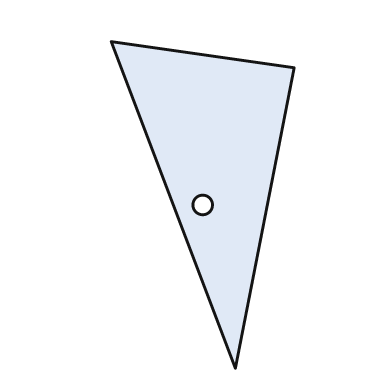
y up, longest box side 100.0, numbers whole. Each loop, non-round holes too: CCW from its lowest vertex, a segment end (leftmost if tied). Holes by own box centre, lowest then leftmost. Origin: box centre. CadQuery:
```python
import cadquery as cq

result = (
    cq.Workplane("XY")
    .moveTo(10.0, -50.0)
    .lineTo(28.0, 42.0)
    .lineTo(-28.0, 50.0)
    .close()
    .moveTo(0.0, 0.0)
    .circle(3.0)
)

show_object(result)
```